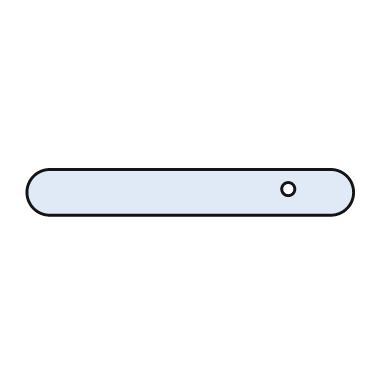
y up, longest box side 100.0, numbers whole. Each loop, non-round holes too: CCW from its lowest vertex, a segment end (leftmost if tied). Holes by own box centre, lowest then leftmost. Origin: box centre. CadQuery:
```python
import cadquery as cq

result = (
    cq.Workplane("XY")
    .moveTo(-43.0, -7.0)
    .lineTo(43.0, -7.0)
    .threePointArc((50.0, 0.0), (43.0, 7.0))
    .lineTo(-43.0, 7.0)
    .threePointArc((-50.0, 0.0), (-43.0, -7.0))
    .close()
    .moveTo(30.0, 1.0)
    .circle(2.0)
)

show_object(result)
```